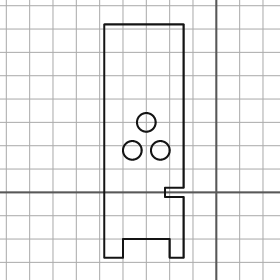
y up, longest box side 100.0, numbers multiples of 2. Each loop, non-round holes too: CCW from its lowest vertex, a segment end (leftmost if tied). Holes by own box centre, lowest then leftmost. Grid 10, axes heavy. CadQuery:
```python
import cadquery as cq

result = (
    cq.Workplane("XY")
    .moveTo(-48.0, -28.0)
    .lineTo(-40.0, -28.0)
    .lineTo(-40.0, -20.0)
    .lineTo(-20.0, -20.0)
    .lineTo(-20.0, -28.0)
    .lineTo(-14.0, -28.0)
    .lineTo(-14.0, -2.0)
    .lineTo(-22.0, -2.0)
    .lineTo(-22.0, 2.0)
    .lineTo(-14.0, 2.0)
    .lineTo(-14.0, 72.0)
    .lineTo(-48.0, 72.0)
    .close()
    .moveTo(-36.0, 18.0)
    .circle(4.0)
    .moveTo(-24.0, 18.0)
    .circle(4.0)
    .moveTo(-30.0, 30.0)
    .circle(4.0)
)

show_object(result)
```